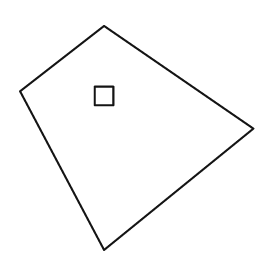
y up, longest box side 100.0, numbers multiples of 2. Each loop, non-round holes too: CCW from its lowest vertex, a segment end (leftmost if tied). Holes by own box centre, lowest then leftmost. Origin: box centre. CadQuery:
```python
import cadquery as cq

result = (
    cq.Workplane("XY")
    .moveTo(-14.0, -48.0)
    .lineTo(50.0, 4.0)
    .lineTo(-14.0, 48.0)
    .lineTo(-50.0, 20.0)
    .close()
    .moveTo(-18.0, 14.0)
    .lineTo(-10.0, 14.0)
    .lineTo(-10.0, 22.0)
    .lineTo(-18.0, 22.0)
    .close()
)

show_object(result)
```